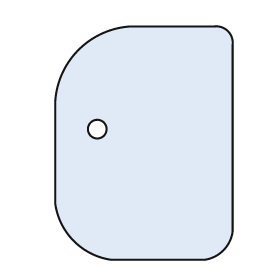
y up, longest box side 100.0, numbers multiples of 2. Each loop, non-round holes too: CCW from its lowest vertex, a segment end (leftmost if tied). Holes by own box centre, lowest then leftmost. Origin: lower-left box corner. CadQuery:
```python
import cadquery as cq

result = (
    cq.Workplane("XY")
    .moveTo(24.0, 0.0)
    .lineTo(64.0, 0.0)
    .threePointArc((72.0, 4.0), (76.0, 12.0))
    .lineTo(76.0, 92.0)
    .threePointArc((74.0, 98.0), (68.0, 100.0))
    .lineTo(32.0, 100.0)
    .threePointArc((10.0, 90.0), (0.0, 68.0))
    .lineTo(0.0, 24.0)
    .threePointArc((8.0, 8.0), (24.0, 0.0))
    .close()
    .moveTo(18.0, 56.0)
    .circle(4.0)
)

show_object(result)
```